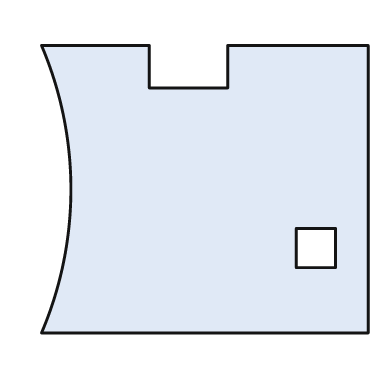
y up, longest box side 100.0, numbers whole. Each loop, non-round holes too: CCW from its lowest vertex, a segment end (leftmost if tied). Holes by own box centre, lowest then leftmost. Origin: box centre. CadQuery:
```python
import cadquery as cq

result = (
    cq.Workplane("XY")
    .moveTo(-50.0, -44.0)
    .lineTo(50.0, -44.0)
    .lineTo(50.0, 44.0)
    .lineTo(7.0, 44.0)
    .lineTo(7.0, 31.0)
    .lineTo(-17.0, 31.0)
    .lineTo(-17.0, 44.0)
    .lineTo(-50.0, 44.0)
    .threePointArc((-41.0, 0.0), (-50.0, -44.0))
    .close()
    .moveTo(28.0, -24.0)
    .lineTo(40.0, -24.0)
    .lineTo(40.0, -12.0)
    .lineTo(28.0, -12.0)
    .close()
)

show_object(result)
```